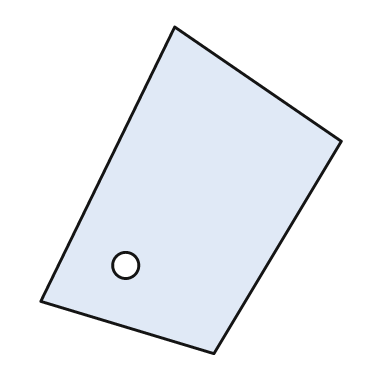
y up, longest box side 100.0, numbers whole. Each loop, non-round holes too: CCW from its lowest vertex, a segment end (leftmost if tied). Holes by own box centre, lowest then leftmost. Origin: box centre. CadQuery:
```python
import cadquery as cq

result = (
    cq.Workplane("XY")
    .moveTo(7.0, -50.0)
    .lineTo(46.0, 15.0)
    .lineTo(-5.0, 50.0)
    .lineTo(-46.0, -34.0)
    .close()
    .moveTo(-20.0, -23.0)
    .circle(4.0)
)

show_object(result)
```